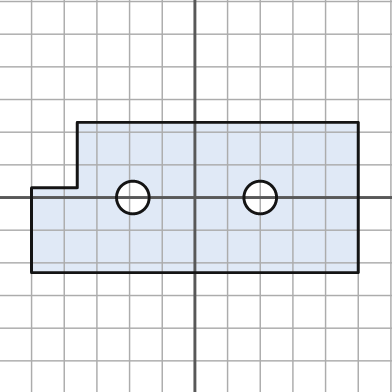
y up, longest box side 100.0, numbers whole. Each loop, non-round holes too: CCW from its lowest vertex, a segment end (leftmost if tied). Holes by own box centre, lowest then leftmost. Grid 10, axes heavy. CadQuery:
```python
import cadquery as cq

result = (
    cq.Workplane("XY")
    .moveTo(-50.0, -23.0)
    .lineTo(50.0, -23.0)
    .lineTo(50.0, 23.0)
    .lineTo(-36.0, 23.0)
    .lineTo(-36.0, 3.0)
    .lineTo(-50.0, 3.0)
    .close()
    .moveTo(-19.0, 0.0)
    .circle(5.0)
    .moveTo(20.0, 0.0)
    .circle(5.0)
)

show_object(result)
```